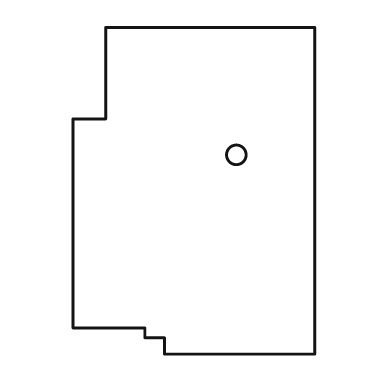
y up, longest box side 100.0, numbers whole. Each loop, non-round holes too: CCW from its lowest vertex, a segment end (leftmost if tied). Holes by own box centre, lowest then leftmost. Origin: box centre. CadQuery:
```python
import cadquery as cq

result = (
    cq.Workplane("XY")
    .moveTo(-9.0, -50.0)
    .lineTo(37.0, -50.0)
    .lineTo(37.0, 50.0)
    .lineTo(-27.0, 50.0)
    .lineTo(-27.0, 22.0)
    .lineTo(-37.0, 22.0)
    .lineTo(-37.0, -42.0)
    .lineTo(-15.0, -42.0)
    .lineTo(-15.0, -45.0)
    .lineTo(-9.0, -45.0)
    .close()
    .moveTo(13.0, 11.0)
    .circle(3.0)
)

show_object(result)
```